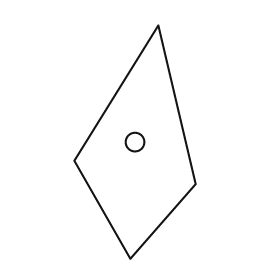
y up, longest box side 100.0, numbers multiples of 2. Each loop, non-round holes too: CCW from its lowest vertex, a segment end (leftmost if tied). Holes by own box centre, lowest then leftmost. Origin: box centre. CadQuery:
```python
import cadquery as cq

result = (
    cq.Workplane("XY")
    .moveTo(-2.0, -50.0)
    .lineTo(26.0, -18.0)
    .lineTo(10.0, 50.0)
    .lineTo(-26.0, -8.0)
    .close()
    .moveTo(0.0, 0.0)
    .circle(4.0)
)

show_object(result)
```